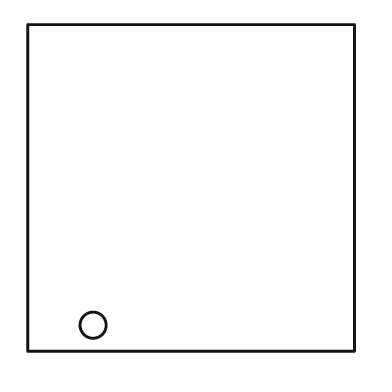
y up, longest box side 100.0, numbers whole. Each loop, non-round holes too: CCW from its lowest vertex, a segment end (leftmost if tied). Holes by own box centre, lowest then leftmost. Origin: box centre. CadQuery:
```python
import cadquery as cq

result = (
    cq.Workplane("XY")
    .moveTo(-50.0, -50.0)
    .lineTo(50.0, -50.0)
    .lineTo(50.0, 50.0)
    .lineTo(-50.0, 50.0)
    .close()
    .moveTo(-30.0, -42.0)
    .circle(4.0)
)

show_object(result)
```